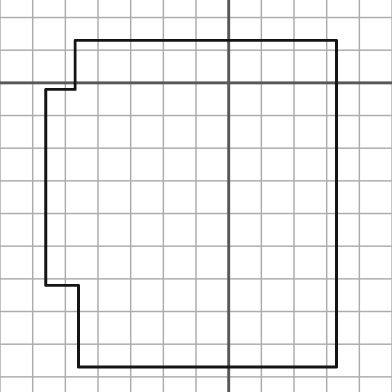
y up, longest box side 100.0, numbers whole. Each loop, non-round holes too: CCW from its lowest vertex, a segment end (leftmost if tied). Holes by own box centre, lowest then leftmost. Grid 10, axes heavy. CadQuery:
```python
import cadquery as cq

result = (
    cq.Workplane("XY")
    .moveTo(-46.0, -87.0)
    .lineTo(33.0, -87.0)
    .lineTo(33.0, 13.0)
    .lineTo(-47.0, 13.0)
    .lineTo(-47.0, -2.0)
    .lineTo(-56.0, -2.0)
    .lineTo(-56.0, -62.0)
    .lineTo(-46.0, -62.0)
    .close()
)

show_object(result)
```